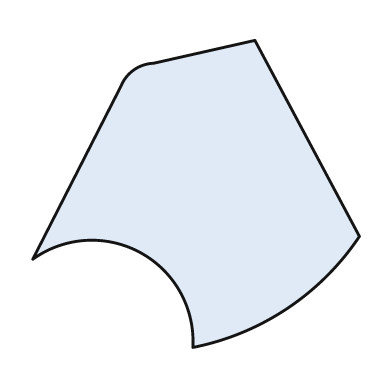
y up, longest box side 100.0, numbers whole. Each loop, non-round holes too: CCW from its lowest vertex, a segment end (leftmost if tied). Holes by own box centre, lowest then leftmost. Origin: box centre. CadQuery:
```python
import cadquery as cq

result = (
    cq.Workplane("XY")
    .moveTo(-1.0, -47.0)
    .threePointArc((28.0, -35.0), (50.0, -13.0))
    .lineTo(18.0, 47.0)
    .lineTo(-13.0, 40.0)
    .threePointArc((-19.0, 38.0), (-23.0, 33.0))
    .lineTo(-50.0, -20.0)
    .threePointArc((-17.0, -18.0), (-1.0, -47.0))
    .close()
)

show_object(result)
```